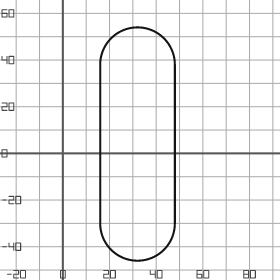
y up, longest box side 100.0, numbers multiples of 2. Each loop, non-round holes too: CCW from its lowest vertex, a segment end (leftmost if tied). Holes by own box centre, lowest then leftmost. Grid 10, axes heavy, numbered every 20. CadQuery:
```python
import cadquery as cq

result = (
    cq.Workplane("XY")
    .moveTo(16.0, -30.0)
    .threePointArc((32.0, -46.0), (48.0, -30.0))
    .lineTo(48.0, 38.0)
    .threePointArc((32.0, 54.0), (16.0, 38.0))
    .close()
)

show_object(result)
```